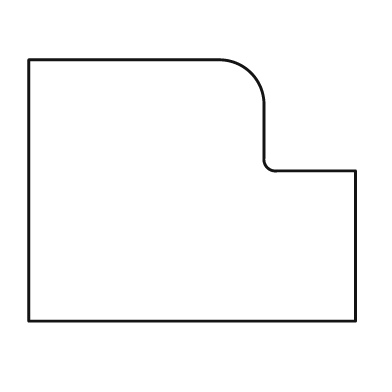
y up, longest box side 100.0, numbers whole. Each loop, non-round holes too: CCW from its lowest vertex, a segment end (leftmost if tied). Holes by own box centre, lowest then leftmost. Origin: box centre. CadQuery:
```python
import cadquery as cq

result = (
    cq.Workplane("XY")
    .moveTo(-50.0, -40.0)
    .lineTo(50.0, -40.0)
    .lineTo(50.0, 6.0)
    .lineTo(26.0, 6.0)
    .threePointArc((23.0, 7.0), (22.0, 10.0))
    .lineTo(22.0, 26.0)
    .threePointArc((18.0, 36.0), (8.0, 40.0))
    .lineTo(-50.0, 40.0)
    .close()
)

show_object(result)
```